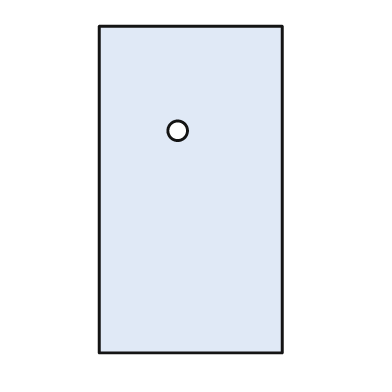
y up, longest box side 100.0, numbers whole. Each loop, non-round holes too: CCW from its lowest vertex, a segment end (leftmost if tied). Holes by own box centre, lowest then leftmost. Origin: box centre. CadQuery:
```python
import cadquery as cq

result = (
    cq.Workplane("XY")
    .moveTo(-28.0, -50.0)
    .lineTo(28.0, -50.0)
    .lineTo(28.0, 50.0)
    .lineTo(-28.0, 50.0)
    .close()
    .moveTo(-4.0, 18.0)
    .circle(3.0)
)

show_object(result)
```